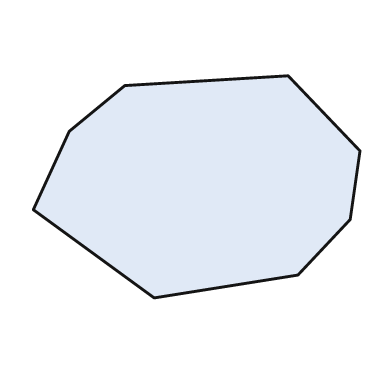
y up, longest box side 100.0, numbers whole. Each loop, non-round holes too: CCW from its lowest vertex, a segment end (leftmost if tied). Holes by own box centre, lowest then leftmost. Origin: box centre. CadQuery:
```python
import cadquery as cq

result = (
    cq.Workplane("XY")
    .moveTo(-13.0, -34.0)
    .lineTo(31.0, -27.0)
    .lineTo(47.0, -10.0)
    .lineTo(50.0, 11.0)
    .lineTo(28.0, 34.0)
    .lineTo(-22.0, 31.0)
    .lineTo(-39.0, 17.0)
    .lineTo(-50.0, -7.0)
    .close()
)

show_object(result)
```